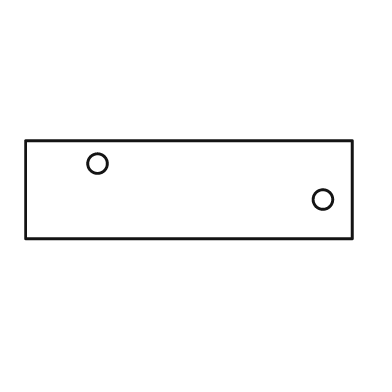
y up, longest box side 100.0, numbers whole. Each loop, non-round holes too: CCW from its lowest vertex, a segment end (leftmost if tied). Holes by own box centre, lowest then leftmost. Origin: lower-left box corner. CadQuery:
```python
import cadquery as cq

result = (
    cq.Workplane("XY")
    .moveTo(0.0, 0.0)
    .lineTo(100.0, 0.0)
    .lineTo(100.0, 30.0)
    .lineTo(0.0, 30.0)
    .close()
    .moveTo(91.0, 12.0)
    .circle(3.0)
    .moveTo(22.0, 23.0)
    .circle(3.0)
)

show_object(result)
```